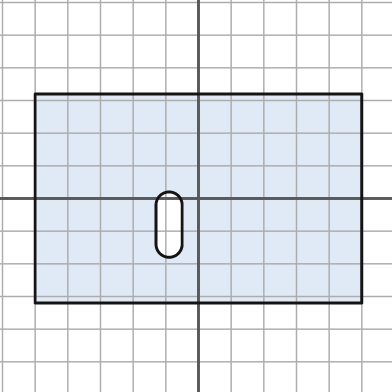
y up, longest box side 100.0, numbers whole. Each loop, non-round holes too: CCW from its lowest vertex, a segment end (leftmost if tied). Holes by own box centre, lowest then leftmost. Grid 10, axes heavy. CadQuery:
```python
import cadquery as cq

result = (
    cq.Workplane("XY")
    .moveTo(-50.0, -32.0)
    .lineTo(50.0, -32.0)
    .lineTo(50.0, 32.0)
    .lineTo(-50.0, 32.0)
    .close()
    .moveTo(-13.0, -14.0)
    .threePointArc((-9.0, -18.0), (-5.0, -14.0))
    .lineTo(-5.0, -2.0)
    .threePointArc((-9.0, 2.0), (-13.0, -2.0))
    .close()
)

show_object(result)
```